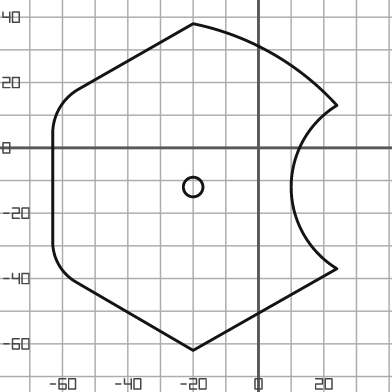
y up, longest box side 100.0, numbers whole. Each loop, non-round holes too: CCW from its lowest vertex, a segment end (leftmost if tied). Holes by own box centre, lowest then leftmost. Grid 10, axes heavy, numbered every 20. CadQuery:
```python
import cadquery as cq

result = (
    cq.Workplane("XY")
    .moveTo(-20.0, -62.0)
    .lineTo(24.0, -37.0)
    .threePointArc((10.0, -12.0), (24.0, 13.0))
    .threePointArc((4.0, 29.0), (-20.0, 38.0))
    .lineTo(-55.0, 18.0)
    .threePointArc((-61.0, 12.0), (-63.0, 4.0))
    .lineTo(-63.0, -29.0)
    .threePointArc((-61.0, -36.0), (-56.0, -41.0))
    .close()
    .moveTo(-20.0, -12.0)
    .circle(3.0)
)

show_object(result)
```